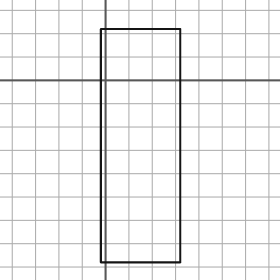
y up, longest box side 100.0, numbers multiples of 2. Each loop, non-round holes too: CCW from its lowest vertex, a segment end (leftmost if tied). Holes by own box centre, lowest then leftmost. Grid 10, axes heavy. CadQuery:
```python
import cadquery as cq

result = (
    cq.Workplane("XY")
    .moveTo(-2.0, -78.0)
    .lineTo(32.0, -78.0)
    .lineTo(32.0, 22.0)
    .lineTo(-2.0, 22.0)
    .close()
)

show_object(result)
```